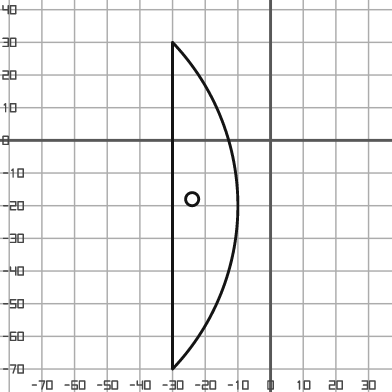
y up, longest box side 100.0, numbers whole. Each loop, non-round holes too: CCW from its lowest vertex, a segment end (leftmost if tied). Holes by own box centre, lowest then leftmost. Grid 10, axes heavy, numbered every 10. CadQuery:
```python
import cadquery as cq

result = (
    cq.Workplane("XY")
    .moveTo(-30.0, -70.0)
    .threePointArc((-10.0, -20.0), (-30.0, 30.0))
    .close()
    .moveTo(-24.0, -18.0)
    .circle(2.0)
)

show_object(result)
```